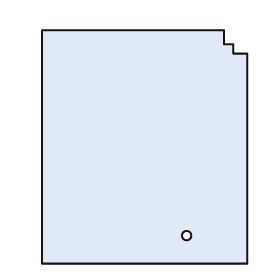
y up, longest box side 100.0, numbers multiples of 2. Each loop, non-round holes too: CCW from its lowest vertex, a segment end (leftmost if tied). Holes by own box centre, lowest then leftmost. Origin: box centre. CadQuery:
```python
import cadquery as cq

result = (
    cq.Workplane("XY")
    .moveTo(-44.0, -50.0)
    .lineTo(44.0, -50.0)
    .lineTo(44.0, 40.0)
    .lineTo(38.0, 40.0)
    .lineTo(38.0, 44.0)
    .lineTo(34.0, 44.0)
    .lineTo(34.0, 50.0)
    .lineTo(-44.0, 50.0)
    .close()
    .moveTo(18.0, -38.0)
    .circle(2.0)
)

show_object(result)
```